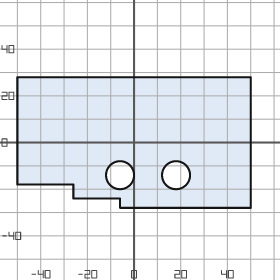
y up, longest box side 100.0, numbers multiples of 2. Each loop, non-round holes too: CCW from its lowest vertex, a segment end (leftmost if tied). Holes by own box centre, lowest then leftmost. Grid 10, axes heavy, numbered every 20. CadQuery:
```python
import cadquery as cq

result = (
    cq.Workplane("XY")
    .moveTo(-6.0, -28.0)
    .lineTo(50.0, -28.0)
    .lineTo(50.0, 28.0)
    .lineTo(-50.0, 28.0)
    .lineTo(-50.0, -18.0)
    .lineTo(-26.0, -18.0)
    .lineTo(-26.0, -24.0)
    .lineTo(-6.0, -24.0)
    .close()
    .moveTo(-6.0, -14.0)
    .circle(6.0)
    .moveTo(18.0, -14.0)
    .circle(6.0)
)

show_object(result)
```